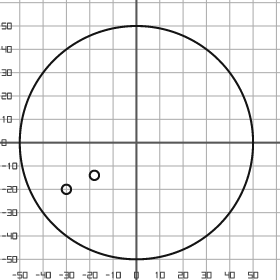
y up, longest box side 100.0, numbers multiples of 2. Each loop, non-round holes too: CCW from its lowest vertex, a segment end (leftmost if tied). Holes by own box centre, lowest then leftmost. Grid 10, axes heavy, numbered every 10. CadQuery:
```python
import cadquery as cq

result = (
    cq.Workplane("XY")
    .moveTo(0.0, 0.0)
    .circle(50.0)
    .moveTo(-30.0, -20.0)
    .circle(2.0)
    .moveTo(-18.0, -14.0)
    .circle(2.0)
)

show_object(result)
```